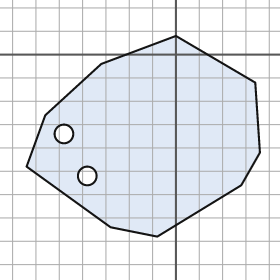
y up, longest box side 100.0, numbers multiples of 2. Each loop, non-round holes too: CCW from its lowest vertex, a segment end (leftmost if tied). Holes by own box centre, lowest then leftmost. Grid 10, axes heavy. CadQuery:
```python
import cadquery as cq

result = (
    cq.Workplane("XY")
    .moveTo(-8.0, -78.0)
    .lineTo(28.0, -56.0)
    .lineTo(36.0, -42.0)
    .lineTo(34.0, -12.0)
    .lineTo(0.0, 8.0)
    .lineTo(-32.0, -4.0)
    .lineTo(-56.0, -26.0)
    .lineTo(-64.0, -48.0)
    .lineTo(-28.0, -74.0)
    .close()
    .moveTo(-38.0, -52.0)
    .circle(4.0)
    .moveTo(-48.0, -34.0)
    .circle(4.0)
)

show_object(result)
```